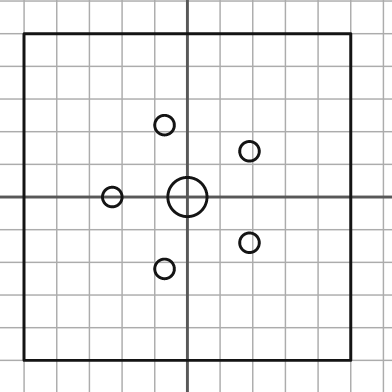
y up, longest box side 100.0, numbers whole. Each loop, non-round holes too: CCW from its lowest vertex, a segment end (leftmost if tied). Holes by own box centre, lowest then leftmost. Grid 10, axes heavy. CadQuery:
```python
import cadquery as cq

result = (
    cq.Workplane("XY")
    .moveTo(-50.0, -50.0)
    .lineTo(50.0, -50.0)
    .lineTo(50.0, 50.0)
    .lineTo(-50.0, 50.0)
    .close()
    .moveTo(-7.0, -22.0)
    .circle(3.0)
    .moveTo(19.0, -14.0)
    .circle(3.0)
    .moveTo(-23.0, 0.0)
    .circle(3.0)
    .moveTo(0.0, 0.0)
    .circle(6.0)
    .moveTo(19.0, 14.0)
    .circle(3.0)
    .moveTo(-7.0, 22.0)
    .circle(3.0)
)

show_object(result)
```